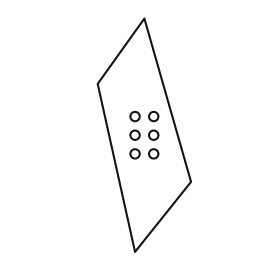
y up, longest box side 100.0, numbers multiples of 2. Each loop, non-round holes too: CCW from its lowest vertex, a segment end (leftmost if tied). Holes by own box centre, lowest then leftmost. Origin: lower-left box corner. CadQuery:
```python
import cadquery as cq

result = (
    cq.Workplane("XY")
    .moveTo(16.0, 0.0)
    .lineTo(40.0, 30.0)
    .lineTo(20.0, 100.0)
    .lineTo(0.0, 72.0)
    .close()
    .moveTo(16.0, 42.0)
    .circle(2.0)
    .moveTo(24.0, 42.0)
    .circle(2.0)
    .moveTo(16.0, 50.0)
    .circle(2.0)
    .moveTo(24.0, 50.0)
    .circle(2.0)
    .moveTo(16.0, 58.0)
    .circle(2.0)
    .moveTo(24.0, 58.0)
    .circle(2.0)
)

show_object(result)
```